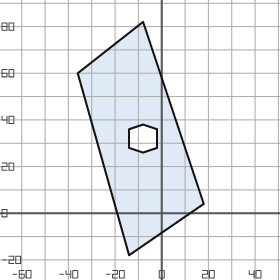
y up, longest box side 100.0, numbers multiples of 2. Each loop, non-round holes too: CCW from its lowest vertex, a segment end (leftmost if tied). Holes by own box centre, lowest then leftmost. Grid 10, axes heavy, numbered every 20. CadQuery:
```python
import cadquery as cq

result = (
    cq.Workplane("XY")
    .moveTo(-14.0, -18.0)
    .lineTo(18.0, 4.0)
    .lineTo(-8.0, 82.0)
    .lineTo(-36.0, 60.0)
    .close()
    .moveTo(-8.0, 26.0)
    .lineTo(-2.0, 28.0)
    .lineTo(-2.0, 36.0)
    .lineTo(-8.0, 38.0)
    .lineTo(-14.0, 36.0)
    .lineTo(-14.0, 28.0)
    .close()
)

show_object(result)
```